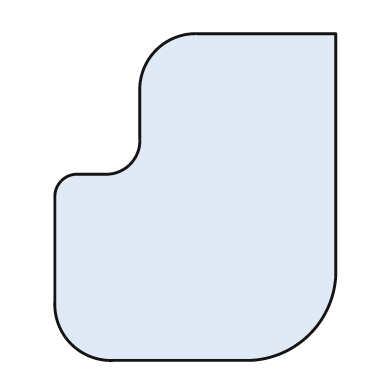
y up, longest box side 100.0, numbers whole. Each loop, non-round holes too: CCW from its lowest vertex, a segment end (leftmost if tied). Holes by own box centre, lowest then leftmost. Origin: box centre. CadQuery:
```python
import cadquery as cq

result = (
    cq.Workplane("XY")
    .moveTo(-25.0, -50.0)
    .lineTo(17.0, -50.0)
    .threePointArc((35.0, -42.0), (43.0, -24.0))
    .lineTo(43.0, 50.0)
    .lineTo(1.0, 50.0)
    .threePointArc((-12.0, 45.0), (-17.0, 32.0))
    .lineTo(-17.0, 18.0)
    .threePointArc((-20.0, 10.0), (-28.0, 7.0))
    .lineTo(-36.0, 7.0)
    .threePointArc((-41.0, 5.0), (-43.0, 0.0))
    .lineTo(-43.0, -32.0)
    .threePointArc((-38.0, -45.0), (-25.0, -50.0))
    .close()
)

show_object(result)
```